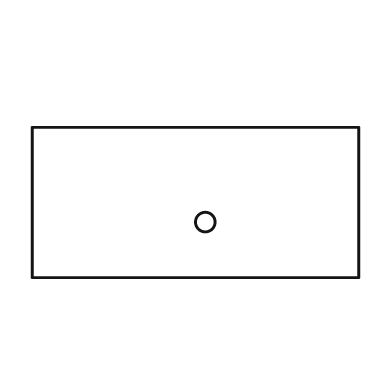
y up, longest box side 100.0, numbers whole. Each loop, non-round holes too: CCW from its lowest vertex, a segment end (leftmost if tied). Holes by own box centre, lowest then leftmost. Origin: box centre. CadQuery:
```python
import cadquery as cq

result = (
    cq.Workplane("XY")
    .moveTo(-50.0, -23.0)
    .lineTo(50.0, -23.0)
    .lineTo(50.0, 23.0)
    .lineTo(-50.0, 23.0)
    .close()
    .moveTo(3.0, -6.0)
    .circle(3.0)
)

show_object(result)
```